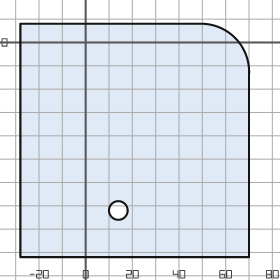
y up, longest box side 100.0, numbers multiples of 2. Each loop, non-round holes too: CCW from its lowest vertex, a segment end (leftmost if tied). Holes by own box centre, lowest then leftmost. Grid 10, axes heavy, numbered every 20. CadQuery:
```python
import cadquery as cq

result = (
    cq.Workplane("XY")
    .moveTo(-28.0, -92.0)
    .lineTo(70.0, -92.0)
    .lineTo(70.0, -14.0)
    .threePointArc((64.0, 2.0), (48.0, 8.0))
    .lineTo(-28.0, 8.0)
    .close()
    .moveTo(14.0, -72.0)
    .circle(4.0)
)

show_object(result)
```